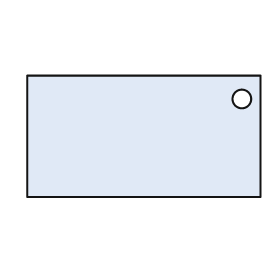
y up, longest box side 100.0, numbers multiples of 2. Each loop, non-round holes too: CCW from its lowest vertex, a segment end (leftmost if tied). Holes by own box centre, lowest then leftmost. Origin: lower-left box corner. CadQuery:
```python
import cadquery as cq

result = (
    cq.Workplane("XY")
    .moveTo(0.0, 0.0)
    .lineTo(100.0, 0.0)
    .lineTo(100.0, 52.0)
    .lineTo(0.0, 52.0)
    .close()
    .moveTo(92.0, 42.0)
    .circle(4.0)
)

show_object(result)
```